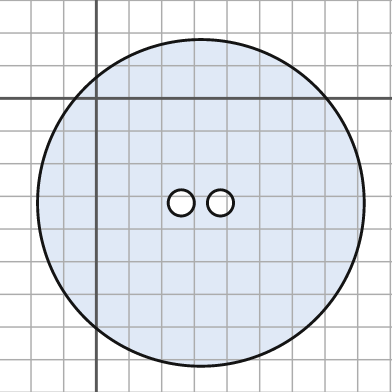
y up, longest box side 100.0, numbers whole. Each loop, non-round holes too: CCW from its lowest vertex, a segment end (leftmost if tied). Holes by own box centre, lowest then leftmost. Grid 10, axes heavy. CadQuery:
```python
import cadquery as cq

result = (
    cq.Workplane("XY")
    .moveTo(32.0, -32.0)
    .circle(50.0)
    .moveTo(26.0, -32.0)
    .circle(4.0)
    .moveTo(38.0, -32.0)
    .circle(4.0)
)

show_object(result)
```